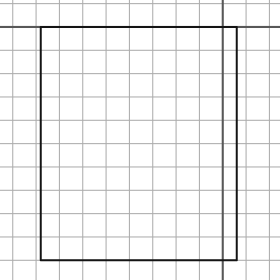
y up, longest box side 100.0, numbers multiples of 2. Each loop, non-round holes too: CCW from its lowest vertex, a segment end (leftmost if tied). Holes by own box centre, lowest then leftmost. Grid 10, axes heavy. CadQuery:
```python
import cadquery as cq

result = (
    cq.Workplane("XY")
    .moveTo(-78.0, -100.0)
    .lineTo(6.0, -100.0)
    .lineTo(6.0, 0.0)
    .lineTo(-78.0, 0.0)
    .close()
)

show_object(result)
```